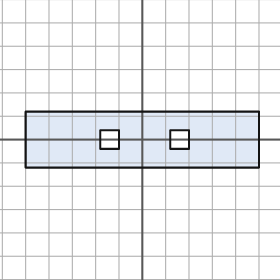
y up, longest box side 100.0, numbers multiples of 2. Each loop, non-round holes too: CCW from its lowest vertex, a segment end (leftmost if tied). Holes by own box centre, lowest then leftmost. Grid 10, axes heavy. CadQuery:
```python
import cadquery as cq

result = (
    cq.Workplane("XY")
    .moveTo(-50.0, -12.0)
    .lineTo(50.0, -12.0)
    .lineTo(50.0, 12.0)
    .lineTo(-50.0, 12.0)
    .close()
    .moveTo(-18.0, -4.0)
    .lineTo(-10.0, -4.0)
    .lineTo(-10.0, 4.0)
    .lineTo(-18.0, 4.0)
    .close()
    .moveTo(12.0, -4.0)
    .lineTo(20.0, -4.0)
    .lineTo(20.0, 4.0)
    .lineTo(12.0, 4.0)
    .close()
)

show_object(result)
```